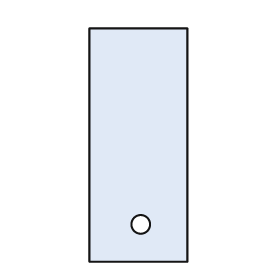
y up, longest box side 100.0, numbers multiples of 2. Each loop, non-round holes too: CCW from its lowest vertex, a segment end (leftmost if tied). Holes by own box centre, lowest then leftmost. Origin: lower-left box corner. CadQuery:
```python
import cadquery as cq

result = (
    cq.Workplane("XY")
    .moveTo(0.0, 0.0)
    .lineTo(42.0, 0.0)
    .lineTo(42.0, 100.0)
    .lineTo(0.0, 100.0)
    .close()
    .moveTo(22.0, 16.0)
    .circle(4.0)
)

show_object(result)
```